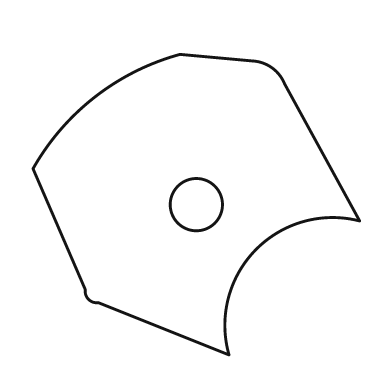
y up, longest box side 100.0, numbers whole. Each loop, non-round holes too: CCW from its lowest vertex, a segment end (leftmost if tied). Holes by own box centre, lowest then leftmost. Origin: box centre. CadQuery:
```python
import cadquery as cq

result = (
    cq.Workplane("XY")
    .moveTo(10.0, -46.0)
    .threePointArc((18.0, -14.0), (50.0, -5.0))
    .lineTo(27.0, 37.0)
    .threePointArc((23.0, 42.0), (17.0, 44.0))
    .lineTo(-5.0, 46.0)
    .threePointArc((-31.0, 33.0), (-50.0, 11.0))
    .lineTo(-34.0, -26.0)
    .threePointArc((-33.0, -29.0), (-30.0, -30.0))
    .close()
    .moveTo(0.0, 0.0)
    .circle(8.0)
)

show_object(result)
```